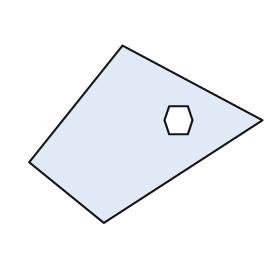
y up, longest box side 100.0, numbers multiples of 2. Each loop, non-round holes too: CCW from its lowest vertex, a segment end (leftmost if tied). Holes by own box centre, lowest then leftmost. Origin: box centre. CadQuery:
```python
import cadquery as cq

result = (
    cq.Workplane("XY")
    .moveTo(-18.0, -38.0)
    .lineTo(50.0, 6.0)
    .lineTo(-10.0, 38.0)
    .lineTo(-50.0, -12.0)
    .close()
    .moveTo(10.0, 0.0)
    .lineTo(18.0, 0.0)
    .lineTo(20.0, 6.0)
    .lineTo(18.0, 12.0)
    .lineTo(10.0, 12.0)
    .lineTo(8.0, 6.0)
    .close()
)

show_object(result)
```